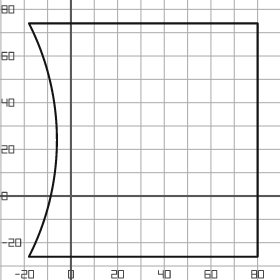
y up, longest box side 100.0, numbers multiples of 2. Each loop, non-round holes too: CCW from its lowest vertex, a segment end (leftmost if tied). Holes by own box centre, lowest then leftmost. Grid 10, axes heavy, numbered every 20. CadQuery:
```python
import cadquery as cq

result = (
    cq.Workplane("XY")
    .moveTo(-18.0, -26.0)
    .lineTo(80.0, -26.0)
    .lineTo(80.0, 74.0)
    .lineTo(-18.0, 74.0)
    .threePointArc((-6.0, 24.0), (-18.0, -26.0))
    .close()
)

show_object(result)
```